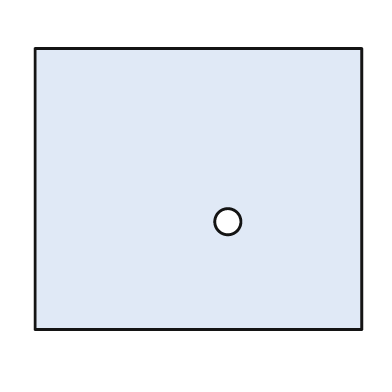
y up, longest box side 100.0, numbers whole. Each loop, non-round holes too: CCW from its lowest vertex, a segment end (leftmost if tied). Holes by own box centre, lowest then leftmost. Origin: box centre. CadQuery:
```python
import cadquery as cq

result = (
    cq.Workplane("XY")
    .moveTo(-50.0, -43.0)
    .lineTo(50.0, -43.0)
    .lineTo(50.0, 43.0)
    .lineTo(-50.0, 43.0)
    .close()
    .moveTo(9.0, -10.0)
    .circle(4.0)
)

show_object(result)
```